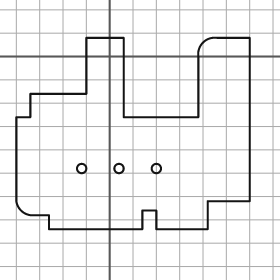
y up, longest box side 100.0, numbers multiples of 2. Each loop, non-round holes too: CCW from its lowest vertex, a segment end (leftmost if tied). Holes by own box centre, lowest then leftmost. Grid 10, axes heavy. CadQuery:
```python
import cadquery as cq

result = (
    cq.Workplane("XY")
    .moveTo(-26.0, -74.0)
    .lineTo(14.0, -74.0)
    .lineTo(14.0, -66.0)
    .lineTo(20.0, -66.0)
    .lineTo(20.0, -74.0)
    .lineTo(42.0, -74.0)
    .lineTo(42.0, -62.0)
    .lineTo(60.0, -62.0)
    .lineTo(60.0, 8.0)
    .lineTo(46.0, 8.0)
    .threePointArc((40.0, 6.0), (38.0, 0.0))
    .lineTo(38.0, -26.0)
    .lineTo(6.0, -26.0)
    .lineTo(6.0, 8.0)
    .lineTo(-10.0, 8.0)
    .lineTo(-10.0, -16.0)
    .lineTo(-34.0, -16.0)
    .lineTo(-34.0, -26.0)
    .lineTo(-40.0, -26.0)
    .lineTo(-40.0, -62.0)
    .threePointArc((-38.0, -66.0), (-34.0, -68.0))
    .lineTo(-26.0, -68.0)
    .close()
    .moveTo(-12.0, -48.0)
    .circle(2.0)
    .moveTo(4.0, -48.0)
    .circle(2.0)
    .moveTo(20.0, -48.0)
    .circle(2.0)
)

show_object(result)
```